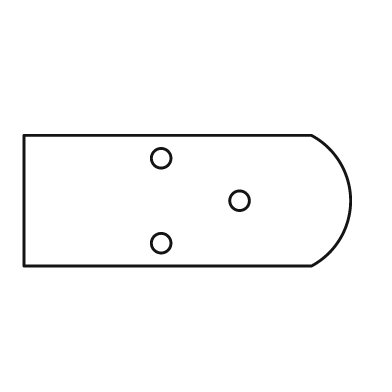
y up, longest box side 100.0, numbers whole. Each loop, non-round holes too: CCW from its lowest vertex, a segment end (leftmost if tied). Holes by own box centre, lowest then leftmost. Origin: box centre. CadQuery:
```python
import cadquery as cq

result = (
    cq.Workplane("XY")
    .moveTo(-50.0, -20.0)
    .lineTo(38.0, -20.0)
    .threePointArc((50.0, 0.0), (38.0, 20.0))
    .lineTo(-50.0, 20.0)
    .close()
    .moveTo(-8.0, -13.0)
    .circle(3.0)
    .moveTo(16.0, 0.0)
    .circle(3.0)
    .moveTo(-8.0, 13.0)
    .circle(3.0)
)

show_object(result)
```